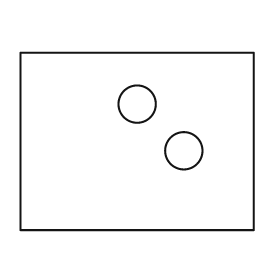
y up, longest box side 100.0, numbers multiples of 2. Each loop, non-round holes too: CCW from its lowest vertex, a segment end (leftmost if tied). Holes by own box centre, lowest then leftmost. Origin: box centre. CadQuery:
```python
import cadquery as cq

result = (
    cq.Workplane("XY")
    .moveTo(-50.0, -38.0)
    .lineTo(50.0, -38.0)
    .lineTo(50.0, 38.0)
    .lineTo(-50.0, 38.0)
    .close()
    .moveTo(20.0, -4.0)
    .circle(8.0)
    .moveTo(0.0, 16.0)
    .circle(8.0)
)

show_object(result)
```